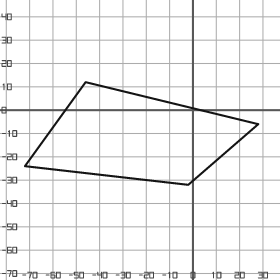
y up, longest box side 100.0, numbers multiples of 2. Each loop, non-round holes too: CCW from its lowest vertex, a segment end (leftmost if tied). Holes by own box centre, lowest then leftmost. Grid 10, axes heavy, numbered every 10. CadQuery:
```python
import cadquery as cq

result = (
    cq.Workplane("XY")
    .moveTo(-2.0, -32.0)
    .lineTo(28.0, -6.0)
    .lineTo(-46.0, 12.0)
    .lineTo(-72.0, -24.0)
    .close()
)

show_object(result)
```